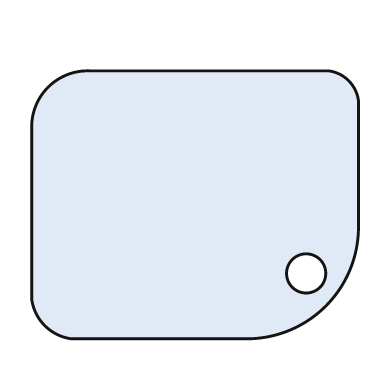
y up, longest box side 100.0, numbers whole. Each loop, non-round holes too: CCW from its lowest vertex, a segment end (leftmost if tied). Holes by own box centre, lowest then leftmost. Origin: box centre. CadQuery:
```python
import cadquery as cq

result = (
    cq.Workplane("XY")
    .moveTo(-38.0, -41.0)
    .lineTo(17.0, -41.0)
    .threePointArc((40.0, -31.0), (50.0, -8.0))
    .lineTo(50.0, 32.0)
    .threePointArc((47.0, 38.0), (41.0, 41.0))
    .lineTo(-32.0, 41.0)
    .threePointArc((-45.0, 36.0), (-50.0, 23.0))
    .lineTo(-50.0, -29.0)
    .threePointArc((-46.0, -37.0), (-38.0, -41.0))
    .close()
    .moveTo(34.0, -21.0)
    .circle(6.0)
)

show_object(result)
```